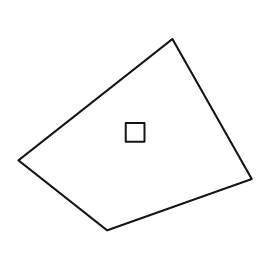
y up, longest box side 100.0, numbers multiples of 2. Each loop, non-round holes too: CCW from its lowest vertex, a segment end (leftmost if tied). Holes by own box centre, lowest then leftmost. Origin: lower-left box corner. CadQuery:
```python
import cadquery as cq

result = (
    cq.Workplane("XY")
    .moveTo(38.0, 0.0)
    .lineTo(100.0, 22.0)
    .lineTo(66.0, 82.0)
    .lineTo(0.0, 30.0)
    .close()
    .moveTo(46.0, 38.0)
    .lineTo(54.0, 38.0)
    .lineTo(54.0, 46.0)
    .lineTo(46.0, 46.0)
    .close()
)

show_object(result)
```